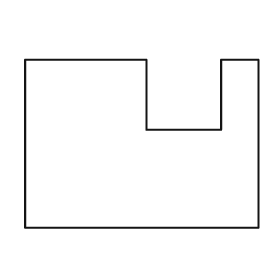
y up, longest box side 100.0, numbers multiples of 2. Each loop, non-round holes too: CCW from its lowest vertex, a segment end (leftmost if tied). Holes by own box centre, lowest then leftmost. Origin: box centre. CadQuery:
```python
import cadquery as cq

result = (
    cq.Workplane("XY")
    .moveTo(-50.0, -36.0)
    .lineTo(50.0, -36.0)
    .lineTo(50.0, 36.0)
    .lineTo(34.0, 36.0)
    .lineTo(34.0, 6.0)
    .lineTo(2.0, 6.0)
    .lineTo(2.0, 36.0)
    .lineTo(-50.0, 36.0)
    .close()
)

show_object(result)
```